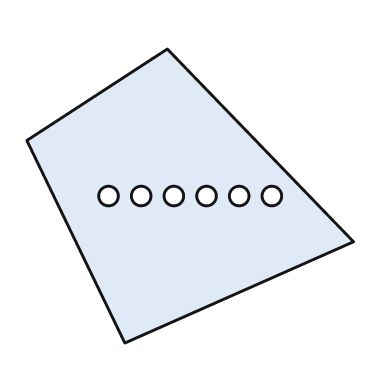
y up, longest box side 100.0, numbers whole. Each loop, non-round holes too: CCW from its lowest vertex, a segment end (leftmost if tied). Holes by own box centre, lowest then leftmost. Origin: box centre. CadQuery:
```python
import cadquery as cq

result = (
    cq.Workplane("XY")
    .moveTo(-20.0, -45.0)
    .lineTo(50.0, -14.0)
    .lineTo(-7.0, 45.0)
    .lineTo(-50.0, 17.0)
    .close()
    .moveTo(-25.0, 0.0)
    .circle(3.0)
    .moveTo(-15.0, 0.0)
    .circle(3.0)
    .moveTo(-5.0, 0.0)
    .circle(3.0)
    .moveTo(5.0, 0.0)
    .circle(3.0)
    .moveTo(15.0, 0.0)
    .circle(3.0)
    .moveTo(25.0, 0.0)
    .circle(3.0)
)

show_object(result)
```